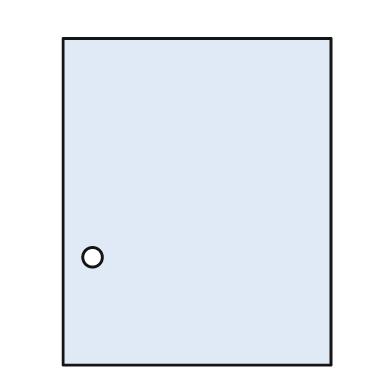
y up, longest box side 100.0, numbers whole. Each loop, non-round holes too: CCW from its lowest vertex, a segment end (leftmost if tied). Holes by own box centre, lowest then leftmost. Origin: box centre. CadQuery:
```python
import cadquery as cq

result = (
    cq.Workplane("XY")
    .moveTo(-41.0, -50.0)
    .lineTo(41.0, -50.0)
    .lineTo(41.0, 50.0)
    .lineTo(-41.0, 50.0)
    .close()
    .moveTo(-32.0, -17.0)
    .circle(3.0)
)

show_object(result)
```